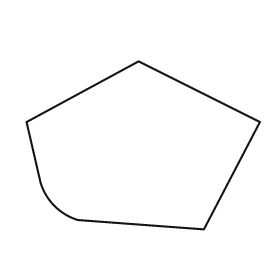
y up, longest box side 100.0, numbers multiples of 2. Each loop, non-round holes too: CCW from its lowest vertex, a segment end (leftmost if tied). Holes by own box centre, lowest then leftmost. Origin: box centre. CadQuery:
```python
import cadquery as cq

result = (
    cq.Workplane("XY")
    .moveTo(26.0, -36.0)
    .lineTo(50.0, 10.0)
    .lineTo(-2.0, 36.0)
    .lineTo(-50.0, 10.0)
    .lineTo(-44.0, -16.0)
    .threePointArc((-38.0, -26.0), (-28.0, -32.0))
    .close()
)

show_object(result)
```